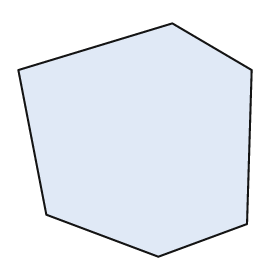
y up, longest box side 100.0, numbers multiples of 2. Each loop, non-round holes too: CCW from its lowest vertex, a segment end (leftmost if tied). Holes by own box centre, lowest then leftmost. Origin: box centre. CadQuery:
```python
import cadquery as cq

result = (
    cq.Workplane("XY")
    .moveTo(10.0, -50.0)
    .lineTo(48.0, -36.0)
    .lineTo(50.0, 30.0)
    .lineTo(16.0, 50.0)
    .lineTo(-50.0, 30.0)
    .lineTo(-38.0, -32.0)
    .close()
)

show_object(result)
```